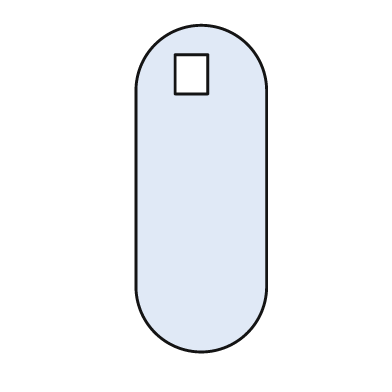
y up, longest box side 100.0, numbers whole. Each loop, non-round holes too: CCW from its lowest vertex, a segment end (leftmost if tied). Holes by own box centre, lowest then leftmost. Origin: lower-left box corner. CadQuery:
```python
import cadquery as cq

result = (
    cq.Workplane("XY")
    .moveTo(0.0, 20.0)
    .threePointArc((20.0, 0.0), (40.0, 20.0))
    .lineTo(40.0, 80.0)
    .threePointArc((20.0, 100.0), (0.0, 80.0))
    .close()
    .moveTo(12.0, 79.0)
    .lineTo(22.0, 79.0)
    .lineTo(22.0, 91.0)
    .lineTo(12.0, 91.0)
    .close()
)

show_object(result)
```